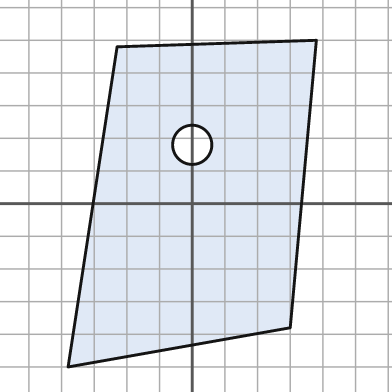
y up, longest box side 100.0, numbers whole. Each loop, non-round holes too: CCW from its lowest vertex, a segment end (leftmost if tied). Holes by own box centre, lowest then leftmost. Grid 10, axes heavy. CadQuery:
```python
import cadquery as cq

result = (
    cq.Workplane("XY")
    .moveTo(-38.0, -50.0)
    .lineTo(30.0, -38.0)
    .lineTo(38.0, 50.0)
    .lineTo(-23.0, 48.0)
    .close()
    .moveTo(0.0, 18.0)
    .circle(6.0)
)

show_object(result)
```